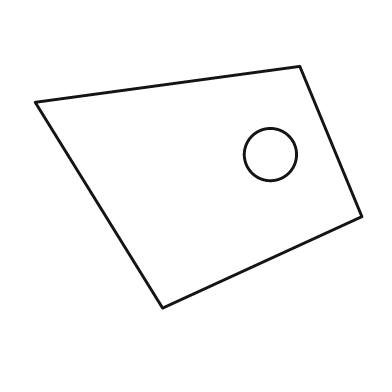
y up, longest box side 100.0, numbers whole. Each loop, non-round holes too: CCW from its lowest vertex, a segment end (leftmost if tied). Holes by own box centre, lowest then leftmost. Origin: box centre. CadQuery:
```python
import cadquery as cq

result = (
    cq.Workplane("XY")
    .moveTo(-11.0, -37.0)
    .lineTo(50.0, -9.0)
    .lineTo(31.0, 37.0)
    .lineTo(-50.0, 26.0)
    .close()
    .moveTo(22.0, 10.0)
    .circle(8.0)
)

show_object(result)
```